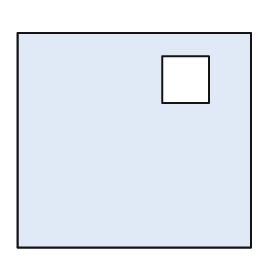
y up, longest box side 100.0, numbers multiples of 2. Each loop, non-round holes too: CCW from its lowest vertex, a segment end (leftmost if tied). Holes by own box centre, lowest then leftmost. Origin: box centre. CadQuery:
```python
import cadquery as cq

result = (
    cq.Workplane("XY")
    .moveTo(-50.0, -46.0)
    .lineTo(50.0, -46.0)
    .lineTo(50.0, 46.0)
    .lineTo(-50.0, 46.0)
    .close()
    .moveTo(12.0, 16.0)
    .lineTo(32.0, 16.0)
    .lineTo(32.0, 36.0)
    .lineTo(12.0, 36.0)
    .close()
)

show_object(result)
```